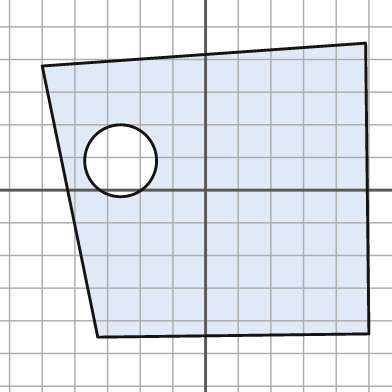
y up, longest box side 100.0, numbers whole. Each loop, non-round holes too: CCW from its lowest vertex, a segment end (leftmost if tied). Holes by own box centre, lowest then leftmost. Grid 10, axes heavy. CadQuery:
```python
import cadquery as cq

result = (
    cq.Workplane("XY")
    .moveTo(-33.0, -45.0)
    .lineTo(50.0, -44.0)
    .lineTo(49.0, 45.0)
    .lineTo(-50.0, 38.0)
    .close()
    .moveTo(-26.0, 9.0)
    .circle(11.0)
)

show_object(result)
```